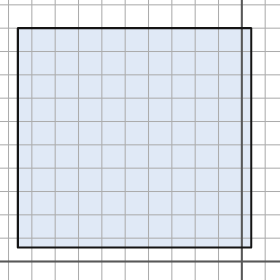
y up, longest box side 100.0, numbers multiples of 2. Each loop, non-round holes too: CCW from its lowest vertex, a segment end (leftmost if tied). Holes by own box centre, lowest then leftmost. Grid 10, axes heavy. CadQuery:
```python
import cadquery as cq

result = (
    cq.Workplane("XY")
    .moveTo(-96.0, 6.0)
    .lineTo(4.0, 6.0)
    .lineTo(4.0, 100.0)
    .lineTo(-96.0, 100.0)
    .close()
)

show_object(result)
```